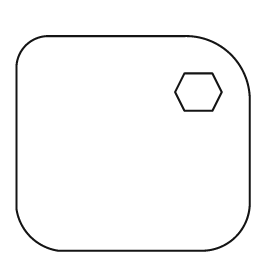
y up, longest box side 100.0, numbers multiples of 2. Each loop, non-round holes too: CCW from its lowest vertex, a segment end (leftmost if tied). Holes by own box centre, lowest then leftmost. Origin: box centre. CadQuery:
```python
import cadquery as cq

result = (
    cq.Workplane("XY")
    .moveTo(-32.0, -46.0)
    .lineTo(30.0, -46.0)
    .threePointArc((44.0, -40.0), (50.0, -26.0))
    .lineTo(50.0, 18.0)
    .threePointArc((42.0, 38.0), (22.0, 46.0))
    .lineTo(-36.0, 46.0)
    .threePointArc((-46.0, 42.0), (-50.0, 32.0))
    .lineTo(-50.0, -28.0)
    .threePointArc((-44.0, -40.0), (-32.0, -46.0))
    .close()
    .moveTo(22.0, 14.0)
    .lineTo(34.0, 14.0)
    .lineTo(38.0, 22.0)
    .lineTo(34.0, 30.0)
    .lineTo(22.0, 30.0)
    .lineTo(18.0, 22.0)
    .close()
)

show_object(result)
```